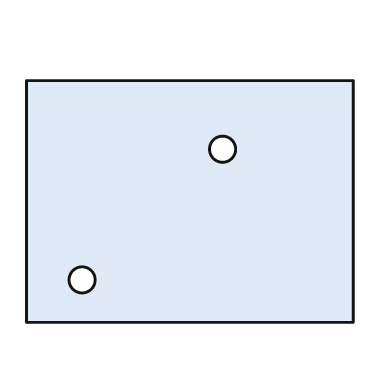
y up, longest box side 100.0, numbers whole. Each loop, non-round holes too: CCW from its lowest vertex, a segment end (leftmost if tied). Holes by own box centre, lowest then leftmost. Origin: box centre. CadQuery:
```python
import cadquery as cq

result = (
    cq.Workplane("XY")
    .moveTo(-50.0, -37.0)
    .lineTo(50.0, -37.0)
    .lineTo(50.0, 37.0)
    .lineTo(-50.0, 37.0)
    .close()
    .moveTo(-33.0, -24.0)
    .circle(4.0)
    .moveTo(10.0, 16.0)
    .circle(4.0)
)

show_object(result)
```